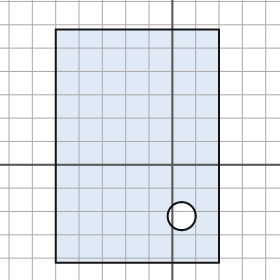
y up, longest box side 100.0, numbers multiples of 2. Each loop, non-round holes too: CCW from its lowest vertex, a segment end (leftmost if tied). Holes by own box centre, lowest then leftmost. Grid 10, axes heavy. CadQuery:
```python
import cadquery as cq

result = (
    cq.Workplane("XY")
    .moveTo(-50.0, -42.0)
    .lineTo(20.0, -42.0)
    .lineTo(20.0, 58.0)
    .lineTo(-50.0, 58.0)
    .close()
    .moveTo(4.0, -22.0)
    .circle(6.0)
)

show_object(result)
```